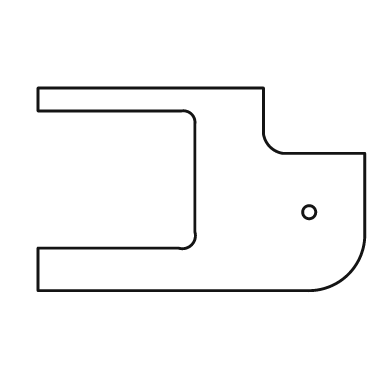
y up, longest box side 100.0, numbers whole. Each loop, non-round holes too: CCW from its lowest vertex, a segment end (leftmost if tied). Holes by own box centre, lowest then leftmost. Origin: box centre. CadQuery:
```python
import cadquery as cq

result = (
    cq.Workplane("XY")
    .moveTo(-50.0, -31.0)
    .lineTo(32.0, -31.0)
    .threePointArc((45.0, -26.0), (50.0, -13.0))
    .lineTo(50.0, 11.0)
    .lineTo(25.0, 11.0)
    .threePointArc((21.0, 13.0), (19.0, 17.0))
    .lineTo(19.0, 31.0)
    .lineTo(-50.0, 31.0)
    .lineTo(-50.0, 24.0)
    .lineTo(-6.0, 24.0)
    .threePointArc((-3.0, 23.0), (-2.0, 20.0))
    .lineTo(-2.0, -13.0)
    .threePointArc((-3.0, -17.0), (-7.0, -18.0))
    .lineTo(-50.0, -18.0)
    .close()
    .moveTo(33.0, -7.0)
    .circle(2.0)
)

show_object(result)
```